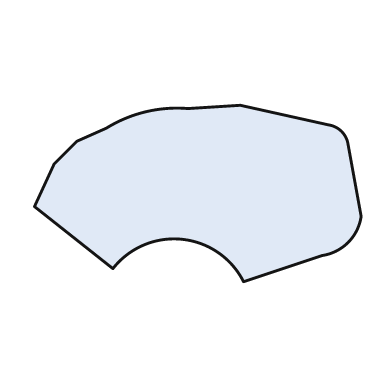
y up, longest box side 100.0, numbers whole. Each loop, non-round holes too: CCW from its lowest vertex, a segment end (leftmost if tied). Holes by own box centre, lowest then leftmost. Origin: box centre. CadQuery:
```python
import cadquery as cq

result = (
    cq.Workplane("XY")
    .moveTo(14.0, -27.0)
    .lineTo(38.0, -19.0)
    .threePointArc((46.0, -15.0), (50.0, -7.0))
    .lineTo(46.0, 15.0)
    .threePointArc((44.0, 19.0), (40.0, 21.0))
    .lineTo(13.0, 27.0)
    .lineTo(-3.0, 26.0)
    .threePointArc((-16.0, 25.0), (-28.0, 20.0))
    .lineTo(-37.0, 16.0)
    .lineTo(-44.0, 9.0)
    .lineTo(-50.0, -4.0)
    .lineTo(-26.0, -23.0)
    .threePointArc((-5.0, -14.0), (14.0, -27.0))
    .close()
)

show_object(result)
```